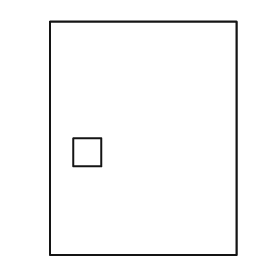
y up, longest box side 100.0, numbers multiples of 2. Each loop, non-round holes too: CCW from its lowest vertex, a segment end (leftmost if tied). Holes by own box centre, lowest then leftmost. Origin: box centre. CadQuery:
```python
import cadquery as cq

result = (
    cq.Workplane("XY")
    .moveTo(-40.0, -50.0)
    .lineTo(40.0, -50.0)
    .lineTo(40.0, 50.0)
    .lineTo(-40.0, 50.0)
    .close()
    .moveTo(-30.0, -12.0)
    .lineTo(-18.0, -12.0)
    .lineTo(-18.0, 0.0)
    .lineTo(-30.0, 0.0)
    .close()
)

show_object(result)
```